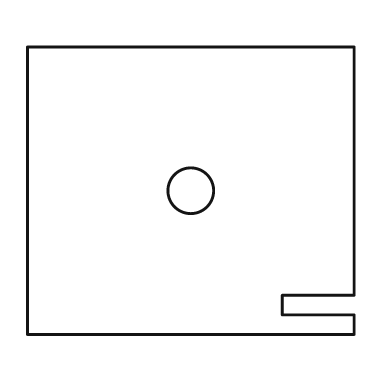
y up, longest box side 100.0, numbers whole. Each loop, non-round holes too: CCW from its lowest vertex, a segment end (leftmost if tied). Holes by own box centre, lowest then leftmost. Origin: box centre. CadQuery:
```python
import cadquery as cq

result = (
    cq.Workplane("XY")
    .moveTo(-50.0, -44.0)
    .lineTo(50.0, -44.0)
    .lineTo(50.0, -38.0)
    .lineTo(28.0, -38.0)
    .lineTo(28.0, -32.0)
    .lineTo(50.0, -32.0)
    .lineTo(50.0, 44.0)
    .lineTo(-50.0, 44.0)
    .close()
    .moveTo(0.0, 0.0)
    .circle(7.0)
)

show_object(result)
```